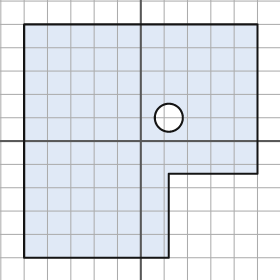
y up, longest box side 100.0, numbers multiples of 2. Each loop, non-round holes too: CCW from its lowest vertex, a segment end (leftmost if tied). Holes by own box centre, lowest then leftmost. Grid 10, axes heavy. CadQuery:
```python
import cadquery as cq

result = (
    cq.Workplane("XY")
    .moveTo(-50.0, -50.0)
    .lineTo(12.0, -50.0)
    .lineTo(12.0, -14.0)
    .lineTo(50.0, -14.0)
    .lineTo(50.0, 50.0)
    .lineTo(-50.0, 50.0)
    .close()
    .moveTo(12.0, 10.0)
    .circle(6.0)
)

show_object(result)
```